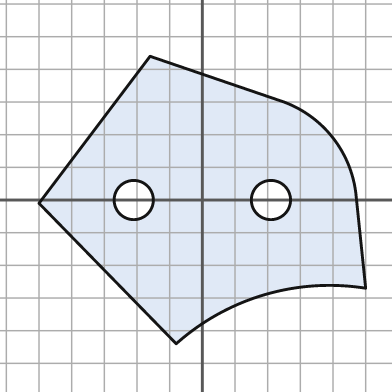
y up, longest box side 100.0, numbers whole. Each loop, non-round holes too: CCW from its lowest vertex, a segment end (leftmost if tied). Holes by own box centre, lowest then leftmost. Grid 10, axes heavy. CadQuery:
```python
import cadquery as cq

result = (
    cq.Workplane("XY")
    .moveTo(-8.0, -44.0)
    .threePointArc((19.0, -29.0), (50.0, -27.0))
    .lineTo(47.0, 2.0)
    .threePointArc((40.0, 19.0), (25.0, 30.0))
    .lineTo(-16.0, 44.0)
    .lineTo(-50.0, -1.0)
    .close()
    .moveTo(-21.0, 0.0)
    .circle(6.0)
    .moveTo(21.0, 0.0)
    .circle(6.0)
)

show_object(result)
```